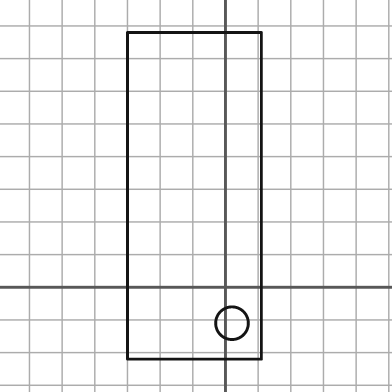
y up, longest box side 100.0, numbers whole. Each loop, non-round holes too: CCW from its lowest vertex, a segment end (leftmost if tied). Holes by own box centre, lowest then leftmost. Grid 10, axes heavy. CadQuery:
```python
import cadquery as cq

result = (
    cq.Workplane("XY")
    .moveTo(-30.0, -22.0)
    .lineTo(11.0, -22.0)
    .lineTo(11.0, 78.0)
    .lineTo(-30.0, 78.0)
    .close()
    .moveTo(2.0, -11.0)
    .circle(5.0)
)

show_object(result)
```